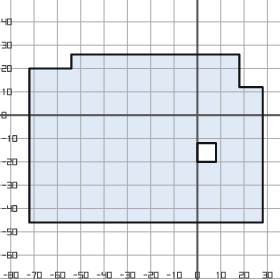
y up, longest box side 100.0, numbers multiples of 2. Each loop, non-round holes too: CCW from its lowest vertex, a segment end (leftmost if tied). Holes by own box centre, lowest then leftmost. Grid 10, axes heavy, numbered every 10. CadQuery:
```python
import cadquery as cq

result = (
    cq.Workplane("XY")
    .moveTo(-72.0, -46.0)
    .lineTo(28.0, -46.0)
    .lineTo(28.0, 12.0)
    .lineTo(18.0, 12.0)
    .lineTo(18.0, 26.0)
    .lineTo(-54.0, 26.0)
    .lineTo(-54.0, 20.0)
    .lineTo(-72.0, 20.0)
    .close()
    .moveTo(0.0, -20.0)
    .lineTo(8.0, -20.0)
    .lineTo(8.0, -12.0)
    .lineTo(0.0, -12.0)
    .close()
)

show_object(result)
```